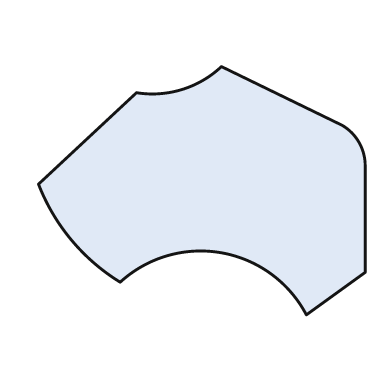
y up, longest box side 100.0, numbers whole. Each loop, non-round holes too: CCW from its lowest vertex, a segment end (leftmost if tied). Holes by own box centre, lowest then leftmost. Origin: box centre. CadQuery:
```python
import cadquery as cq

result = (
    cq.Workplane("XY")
    .moveTo(32.0, -38.0)
    .lineTo(50.0, -25.0)
    .lineTo(50.0, 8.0)
    .threePointArc((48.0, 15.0), (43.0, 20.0))
    .lineTo(6.0, 38.0)
    .threePointArc((-6.0, 31.0), (-20.0, 30.0))
    .lineTo(-50.0, 2.0)
    .threePointArc((-40.0, -15.0), (-25.0, -28.0))
    .threePointArc((6.0, -19.0), (32.0, -38.0))
    .close()
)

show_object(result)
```